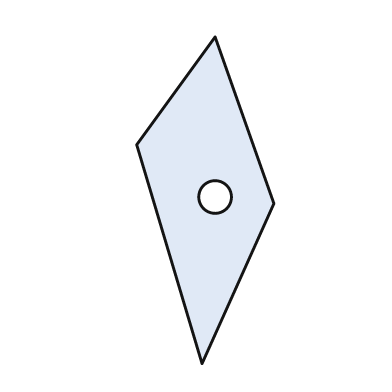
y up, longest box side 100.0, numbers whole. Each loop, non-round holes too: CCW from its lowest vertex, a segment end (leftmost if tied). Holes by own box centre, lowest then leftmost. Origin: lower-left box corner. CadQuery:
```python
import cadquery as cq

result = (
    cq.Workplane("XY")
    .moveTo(20.0, 0.0)
    .lineTo(42.0, 49.0)
    .lineTo(24.0, 100.0)
    .lineTo(0.0, 67.0)
    .close()
    .moveTo(24.0, 51.0)
    .circle(5.0)
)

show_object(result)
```